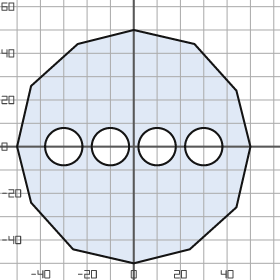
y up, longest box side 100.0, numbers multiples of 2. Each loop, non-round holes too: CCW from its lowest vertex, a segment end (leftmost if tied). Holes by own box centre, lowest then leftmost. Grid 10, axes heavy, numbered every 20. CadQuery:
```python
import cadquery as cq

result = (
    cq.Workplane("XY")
    .moveTo(0.0, -50.0)
    .lineTo(24.0, -44.0)
    .lineTo(44.0, -26.0)
    .lineTo(50.0, 0.0)
    .lineTo(44.0, 24.0)
    .lineTo(26.0, 44.0)
    .lineTo(0.0, 50.0)
    .lineTo(-24.0, 44.0)
    .lineTo(-44.0, 26.0)
    .lineTo(-50.0, 0.0)
    .lineTo(-44.0, -24.0)
    .lineTo(-26.0, -44.0)
    .close()
    .moveTo(-30.0, 0.0)
    .circle(8.0)
    .moveTo(-10.0, 0.0)
    .circle(8.0)
    .moveTo(10.0, 0.0)
    .circle(8.0)
    .moveTo(30.0, 0.0)
    .circle(8.0)
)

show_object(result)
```